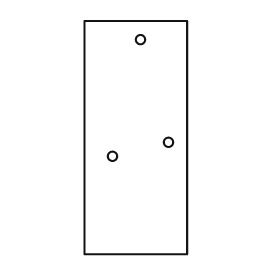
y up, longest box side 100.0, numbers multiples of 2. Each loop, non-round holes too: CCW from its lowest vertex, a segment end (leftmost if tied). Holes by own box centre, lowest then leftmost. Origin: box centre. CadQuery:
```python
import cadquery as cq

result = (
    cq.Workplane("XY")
    .moveTo(-22.0, -50.0)
    .lineTo(22.0, -50.0)
    .lineTo(22.0, 50.0)
    .lineTo(-22.0, 50.0)
    .close()
    .moveTo(-10.0, -8.0)
    .circle(2.0)
    .moveTo(14.0, -2.0)
    .circle(2.0)
    .moveTo(2.0, 42.0)
    .circle(2.0)
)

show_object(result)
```